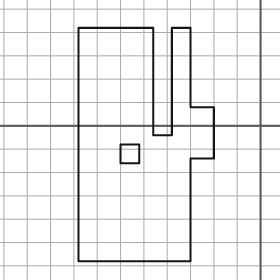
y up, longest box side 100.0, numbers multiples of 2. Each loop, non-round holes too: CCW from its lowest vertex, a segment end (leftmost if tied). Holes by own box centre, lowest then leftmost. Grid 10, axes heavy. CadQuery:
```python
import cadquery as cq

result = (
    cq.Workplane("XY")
    .moveTo(-78.0, -58.0)
    .lineTo(-30.0, -58.0)
    .lineTo(-30.0, -14.0)
    .lineTo(-20.0, -14.0)
    .lineTo(-20.0, 8.0)
    .lineTo(-30.0, 8.0)
    .lineTo(-30.0, 42.0)
    .lineTo(-38.0, 42.0)
    .lineTo(-38.0, -4.0)
    .lineTo(-46.0, -4.0)
    .lineTo(-46.0, 42.0)
    .lineTo(-78.0, 42.0)
    .close()
    .moveTo(-60.0, -16.0)
    .lineTo(-52.0, -16.0)
    .lineTo(-52.0, -8.0)
    .lineTo(-60.0, -8.0)
    .close()
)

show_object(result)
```